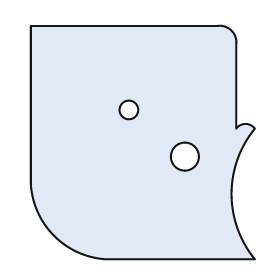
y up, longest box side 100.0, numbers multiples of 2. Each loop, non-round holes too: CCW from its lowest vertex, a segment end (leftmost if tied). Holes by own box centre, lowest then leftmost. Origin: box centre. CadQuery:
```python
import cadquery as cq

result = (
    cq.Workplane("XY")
    .moveTo(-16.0, -50.0)
    .lineTo(48.0, -50.0)
    .threePointArc((38.0, -22.0), (48.0, 6.0))
    .threePointArc((44.0, 8.0), (40.0, 6.0))
    .lineTo(40.0, 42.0)
    .threePointArc((38.0, 48.0), (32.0, 50.0))
    .lineTo(-48.0, 50.0)
    .lineTo(-48.0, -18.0)
    .threePointArc((-38.0, -40.0), (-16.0, -50.0))
    .close()
    .moveTo(18.0, -6.0)
    .circle(6.0)
    .moveTo(-6.0, 14.0)
    .circle(4.0)
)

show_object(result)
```